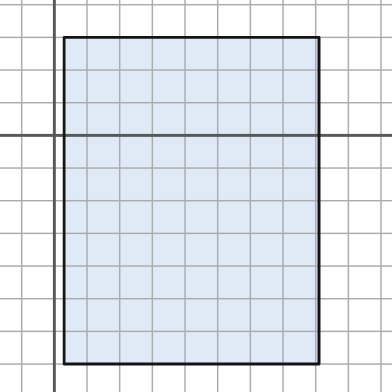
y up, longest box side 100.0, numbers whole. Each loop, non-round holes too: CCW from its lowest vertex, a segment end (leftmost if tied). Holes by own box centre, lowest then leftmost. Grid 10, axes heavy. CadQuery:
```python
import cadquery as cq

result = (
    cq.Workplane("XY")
    .moveTo(3.0, -70.0)
    .lineTo(81.0, -70.0)
    .lineTo(81.0, 30.0)
    .lineTo(3.0, 30.0)
    .close()
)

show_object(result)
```